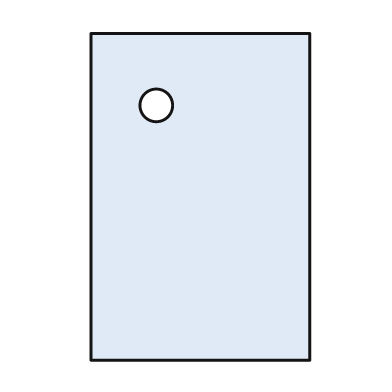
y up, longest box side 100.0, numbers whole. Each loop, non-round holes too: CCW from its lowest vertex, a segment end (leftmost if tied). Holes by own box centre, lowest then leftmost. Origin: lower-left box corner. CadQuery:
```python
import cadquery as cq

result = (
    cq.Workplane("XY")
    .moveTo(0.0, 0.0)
    .lineTo(67.0, 0.0)
    .lineTo(67.0, 100.0)
    .lineTo(0.0, 100.0)
    .close()
    .moveTo(20.0, 78.0)
    .circle(5.0)
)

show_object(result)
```